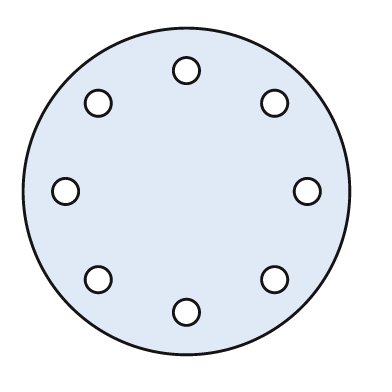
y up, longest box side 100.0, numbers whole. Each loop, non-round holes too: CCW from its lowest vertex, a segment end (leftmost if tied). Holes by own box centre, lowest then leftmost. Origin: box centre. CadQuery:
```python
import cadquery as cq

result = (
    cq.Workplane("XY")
    .moveTo(0.0, 0.0)
    .circle(50.0)
    .moveTo(0.0, -37.0)
    .circle(4.0)
    .moveTo(-27.0, -27.0)
    .circle(4.0)
    .moveTo(27.0, -27.0)
    .circle(4.0)
    .moveTo(-37.0, 0.0)
    .circle(4.0)
    .moveTo(37.0, 0.0)
    .circle(4.0)
    .moveTo(-27.0, 27.0)
    .circle(4.0)
    .moveTo(27.0, 27.0)
    .circle(4.0)
    .moveTo(0.0, 37.0)
    .circle(4.0)
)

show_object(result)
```